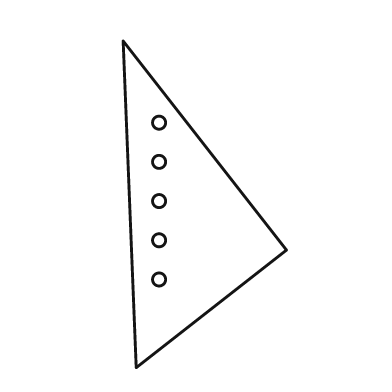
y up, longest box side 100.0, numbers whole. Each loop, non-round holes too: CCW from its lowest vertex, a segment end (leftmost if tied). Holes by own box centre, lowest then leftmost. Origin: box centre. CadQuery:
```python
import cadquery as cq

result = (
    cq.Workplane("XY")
    .moveTo(-21.0, -50.0)
    .lineTo(25.0, -14.0)
    .lineTo(-25.0, 50.0)
    .close()
    .moveTo(-14.0, -23.0)
    .circle(2.0)
    .moveTo(-14.0, -11.0)
    .circle(2.0)
    .moveTo(-14.0, 1.0)
    .circle(2.0)
    .moveTo(-14.0, 13.0)
    .circle(2.0)
    .moveTo(-14.0, 25.0)
    .circle(2.0)
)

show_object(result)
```